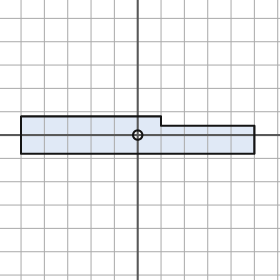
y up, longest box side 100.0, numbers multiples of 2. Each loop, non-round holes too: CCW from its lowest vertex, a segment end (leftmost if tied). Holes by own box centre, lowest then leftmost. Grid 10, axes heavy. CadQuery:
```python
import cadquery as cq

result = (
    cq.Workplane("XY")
    .moveTo(-50.0, -8.0)
    .lineTo(50.0, -8.0)
    .lineTo(50.0, 4.0)
    .lineTo(10.0, 4.0)
    .lineTo(10.0, 8.0)
    .lineTo(-50.0, 8.0)
    .close()
    .moveTo(0.0, 0.0)
    .circle(2.0)
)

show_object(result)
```